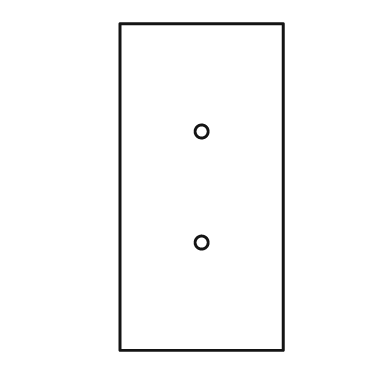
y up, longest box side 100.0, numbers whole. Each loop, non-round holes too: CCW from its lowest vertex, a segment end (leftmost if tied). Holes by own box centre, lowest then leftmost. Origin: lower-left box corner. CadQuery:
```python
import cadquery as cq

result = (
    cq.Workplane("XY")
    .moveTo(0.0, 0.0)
    .lineTo(50.0, 0.0)
    .lineTo(50.0, 100.0)
    .lineTo(0.0, 100.0)
    .close()
    .moveTo(25.0, 33.0)
    .circle(2.0)
    .moveTo(25.0, 67.0)
    .circle(2.0)
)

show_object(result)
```